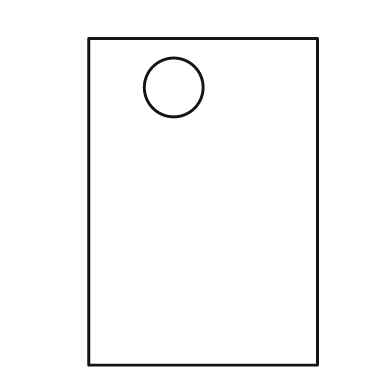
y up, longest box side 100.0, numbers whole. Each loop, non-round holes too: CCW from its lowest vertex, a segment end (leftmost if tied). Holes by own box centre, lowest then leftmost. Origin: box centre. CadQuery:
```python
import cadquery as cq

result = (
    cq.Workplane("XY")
    .moveTo(-35.0, -50.0)
    .lineTo(35.0, -50.0)
    .lineTo(35.0, 50.0)
    .lineTo(-35.0, 50.0)
    .close()
    .moveTo(-9.0, 35.0)
    .circle(9.0)
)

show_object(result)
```